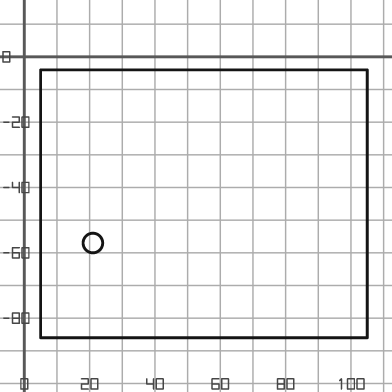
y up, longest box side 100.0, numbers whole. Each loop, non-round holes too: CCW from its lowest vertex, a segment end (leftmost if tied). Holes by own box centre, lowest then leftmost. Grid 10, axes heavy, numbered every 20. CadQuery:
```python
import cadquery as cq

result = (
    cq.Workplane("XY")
    .moveTo(5.0, -86.0)
    .lineTo(105.0, -86.0)
    .lineTo(105.0, -4.0)
    .lineTo(5.0, -4.0)
    .close()
    .moveTo(21.0, -57.0)
    .circle(3.0)
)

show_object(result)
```